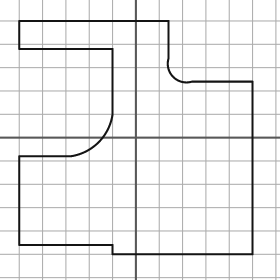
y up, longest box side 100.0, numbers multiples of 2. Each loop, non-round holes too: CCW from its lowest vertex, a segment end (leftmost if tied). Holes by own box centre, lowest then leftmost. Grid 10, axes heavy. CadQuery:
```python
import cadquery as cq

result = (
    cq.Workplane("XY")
    .moveTo(-10.0, -50.0)
    .lineTo(50.0, -50.0)
    .lineTo(50.0, 24.0)
    .lineTo(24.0, 24.0)
    .threePointArc((16.0, 26.0), (14.0, 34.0))
    .lineTo(14.0, 50.0)
    .lineTo(-50.0, 50.0)
    .lineTo(-50.0, 38.0)
    .lineTo(-10.0, 38.0)
    .lineTo(-10.0, 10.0)
    .threePointArc((-16.0, -2.0), (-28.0, -8.0))
    .lineTo(-50.0, -8.0)
    .lineTo(-50.0, -46.0)
    .lineTo(-10.0, -46.0)
    .close()
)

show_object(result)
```